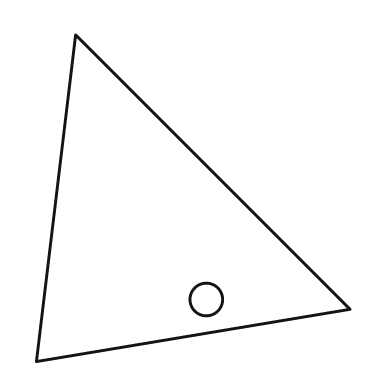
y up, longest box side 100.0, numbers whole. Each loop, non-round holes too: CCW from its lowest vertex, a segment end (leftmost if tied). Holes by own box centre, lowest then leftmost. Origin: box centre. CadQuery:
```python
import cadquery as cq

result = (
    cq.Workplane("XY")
    .moveTo(-48.0, -50.0)
    .lineTo(48.0, -34.0)
    .lineTo(-36.0, 50.0)
    .close()
    .moveTo(4.0, -31.0)
    .circle(5.0)
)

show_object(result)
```